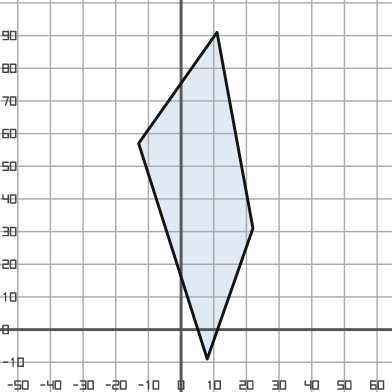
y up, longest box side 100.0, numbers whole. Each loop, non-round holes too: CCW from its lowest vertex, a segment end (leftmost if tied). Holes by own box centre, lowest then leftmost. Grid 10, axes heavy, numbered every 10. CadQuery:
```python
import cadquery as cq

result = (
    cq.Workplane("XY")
    .moveTo(8.0, -9.0)
    .lineTo(22.0, 31.0)
    .lineTo(11.0, 91.0)
    .lineTo(-13.0, 57.0)
    .close()
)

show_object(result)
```